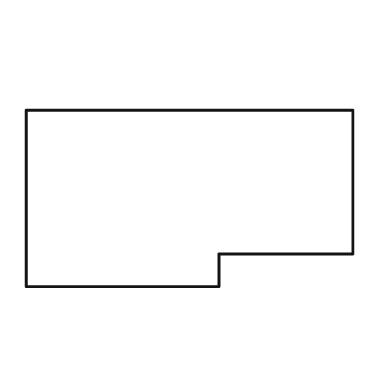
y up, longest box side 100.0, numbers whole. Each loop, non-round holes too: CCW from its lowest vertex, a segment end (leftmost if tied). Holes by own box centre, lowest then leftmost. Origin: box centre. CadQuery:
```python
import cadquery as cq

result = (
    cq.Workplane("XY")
    .moveTo(-50.0, -27.0)
    .lineTo(9.0, -27.0)
    .lineTo(9.0, -17.0)
    .lineTo(50.0, -17.0)
    .lineTo(50.0, 27.0)
    .lineTo(-50.0, 27.0)
    .close()
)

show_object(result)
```